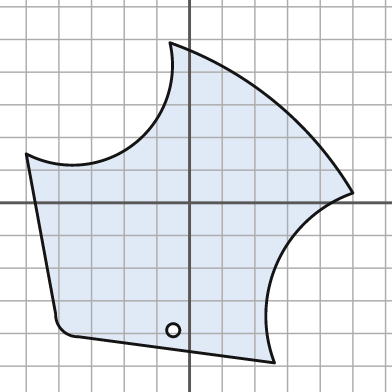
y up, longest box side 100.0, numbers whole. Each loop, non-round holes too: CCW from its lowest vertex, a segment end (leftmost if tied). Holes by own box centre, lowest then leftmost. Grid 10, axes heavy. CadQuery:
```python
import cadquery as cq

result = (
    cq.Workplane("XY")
    .moveTo(26.0, -49.0)
    .threePointArc((27.0, -18.0), (50.0, 3.0))
    .threePointArc((26.0, 31.0), (-6.0, 49.0))
    .threePointArc((-17.0, 18.0), (-50.0, 15.0))
    .lineTo(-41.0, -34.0)
    .threePointArc((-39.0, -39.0), (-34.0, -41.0))
    .close()
    .moveTo(-5.0, -39.0)
    .circle(2.0)
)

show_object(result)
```